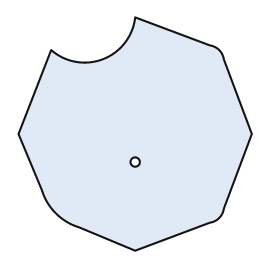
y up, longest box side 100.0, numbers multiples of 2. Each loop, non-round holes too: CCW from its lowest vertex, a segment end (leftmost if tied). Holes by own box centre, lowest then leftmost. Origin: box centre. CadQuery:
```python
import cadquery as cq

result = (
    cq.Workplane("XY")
    .moveTo(0.0, -50.0)
    .lineTo(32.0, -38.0)
    .threePointArc((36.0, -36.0), (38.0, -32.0))
    .lineTo(50.0, 0.0)
    .lineTo(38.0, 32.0)
    .threePointArc((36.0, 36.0), (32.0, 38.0))
    .lineTo(0.0, 50.0)
    .threePointArc((-14.0, 32.0), (-36.0, 36.0))
    .lineTo(-50.0, 0.0)
    .lineTo(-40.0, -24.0)
    .threePointArc((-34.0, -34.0), (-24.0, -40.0))
    .close()
    .moveTo(0.0, -12.0)
    .circle(2.0)
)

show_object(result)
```